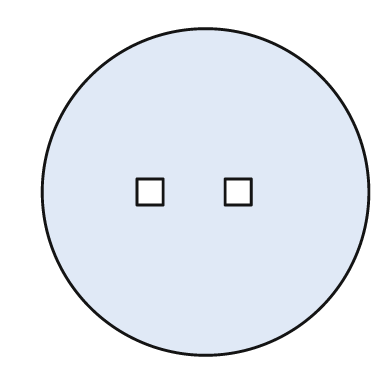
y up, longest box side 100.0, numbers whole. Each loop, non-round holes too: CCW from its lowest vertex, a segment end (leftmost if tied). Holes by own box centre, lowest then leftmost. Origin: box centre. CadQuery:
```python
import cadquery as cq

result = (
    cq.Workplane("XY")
    .moveTo(0.0, 0.0)
    .circle(50.0)
    .moveTo(-21.0, -4.0)
    .lineTo(-13.0, -4.0)
    .lineTo(-13.0, 4.0)
    .lineTo(-21.0, 4.0)
    .close()
    .moveTo(6.0, -4.0)
    .lineTo(14.0, -4.0)
    .lineTo(14.0, 4.0)
    .lineTo(6.0, 4.0)
    .close()
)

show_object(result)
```